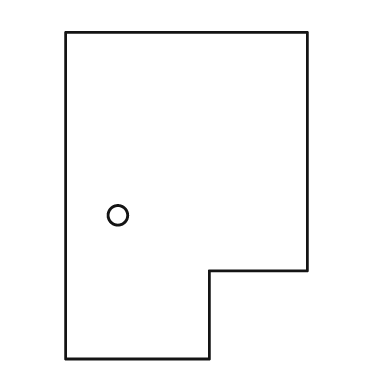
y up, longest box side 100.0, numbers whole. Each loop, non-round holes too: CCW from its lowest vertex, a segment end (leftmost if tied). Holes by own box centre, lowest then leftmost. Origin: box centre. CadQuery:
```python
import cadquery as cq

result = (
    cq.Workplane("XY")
    .moveTo(-37.0, -50.0)
    .lineTo(7.0, -50.0)
    .lineTo(7.0, -23.0)
    .lineTo(37.0, -23.0)
    .lineTo(37.0, 50.0)
    .lineTo(-37.0, 50.0)
    .close()
    .moveTo(-21.0, -6.0)
    .circle(3.0)
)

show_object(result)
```